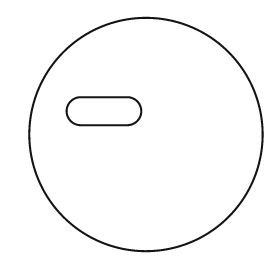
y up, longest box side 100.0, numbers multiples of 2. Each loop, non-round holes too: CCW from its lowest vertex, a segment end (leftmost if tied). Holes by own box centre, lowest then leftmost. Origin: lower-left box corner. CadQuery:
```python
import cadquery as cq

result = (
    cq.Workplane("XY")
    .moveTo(50.0, 50.0)
    .circle(50.0)
    .moveTo(22.0, 54.0)
    .lineTo(42.0, 54.0)
    .threePointArc((48.0, 60.0), (42.0, 66.0))
    .lineTo(22.0, 66.0)
    .threePointArc((16.0, 60.0), (22.0, 54.0))
    .close()
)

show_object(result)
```